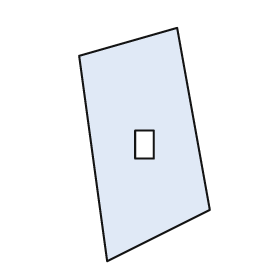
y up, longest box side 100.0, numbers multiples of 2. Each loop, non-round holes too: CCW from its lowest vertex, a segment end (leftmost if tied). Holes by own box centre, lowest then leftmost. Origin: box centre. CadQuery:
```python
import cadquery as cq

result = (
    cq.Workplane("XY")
    .moveTo(-16.0, -50.0)
    .lineTo(28.0, -28.0)
    .lineTo(14.0, 50.0)
    .lineTo(-28.0, 38.0)
    .close()
    .moveTo(-4.0, -6.0)
    .lineTo(4.0, -6.0)
    .lineTo(4.0, 6.0)
    .lineTo(-4.0, 6.0)
    .close()
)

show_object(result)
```